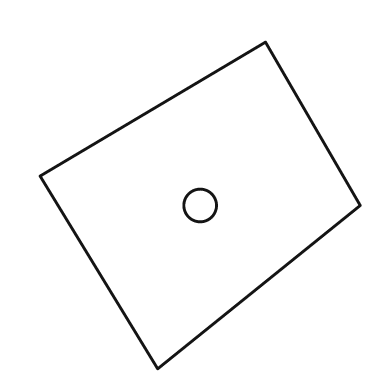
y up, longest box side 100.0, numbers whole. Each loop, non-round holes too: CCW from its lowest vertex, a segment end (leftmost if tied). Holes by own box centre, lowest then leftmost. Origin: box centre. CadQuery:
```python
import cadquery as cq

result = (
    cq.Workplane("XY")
    .moveTo(-13.0, -50.0)
    .lineTo(49.0, 0.0)
    .lineTo(20.0, 50.0)
    .lineTo(-49.0, 9.0)
    .close()
    .moveTo(0.0, 0.0)
    .circle(5.0)
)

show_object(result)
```